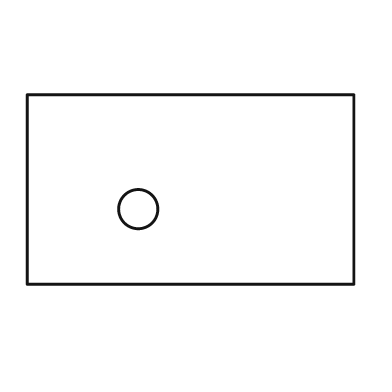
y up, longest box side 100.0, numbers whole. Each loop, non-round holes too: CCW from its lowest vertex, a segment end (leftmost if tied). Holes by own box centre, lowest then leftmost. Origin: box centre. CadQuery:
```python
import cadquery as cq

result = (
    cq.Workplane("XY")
    .moveTo(-50.0, -29.0)
    .lineTo(50.0, -29.0)
    .lineTo(50.0, 29.0)
    .lineTo(-50.0, 29.0)
    .close()
    .moveTo(-16.0, -6.0)
    .circle(6.0)
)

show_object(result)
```